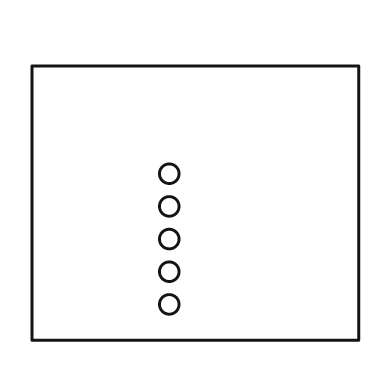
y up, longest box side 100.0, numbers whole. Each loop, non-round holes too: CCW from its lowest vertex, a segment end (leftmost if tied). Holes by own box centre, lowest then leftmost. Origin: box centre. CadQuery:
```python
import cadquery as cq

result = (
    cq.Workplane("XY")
    .moveTo(-50.0, -42.0)
    .lineTo(50.0, -42.0)
    .lineTo(50.0, 42.0)
    .lineTo(-50.0, 42.0)
    .close()
    .moveTo(-8.0, -31.0)
    .circle(3.0)
    .moveTo(-8.0, -21.0)
    .circle(3.0)
    .moveTo(-8.0, -11.0)
    .circle(3.0)
    .moveTo(-8.0, -1.0)
    .circle(3.0)
    .moveTo(-8.0, 9.0)
    .circle(3.0)
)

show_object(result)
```